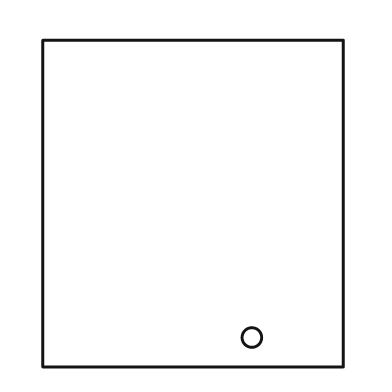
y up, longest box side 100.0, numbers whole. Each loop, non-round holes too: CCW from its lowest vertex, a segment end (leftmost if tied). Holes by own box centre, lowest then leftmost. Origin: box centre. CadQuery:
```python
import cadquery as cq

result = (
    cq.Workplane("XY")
    .moveTo(-46.0, -50.0)
    .lineTo(46.0, -50.0)
    .lineTo(46.0, 50.0)
    .lineTo(-46.0, 50.0)
    .close()
    .moveTo(18.0, -41.0)
    .circle(3.0)
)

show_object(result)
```